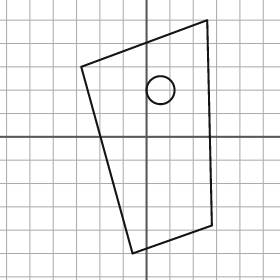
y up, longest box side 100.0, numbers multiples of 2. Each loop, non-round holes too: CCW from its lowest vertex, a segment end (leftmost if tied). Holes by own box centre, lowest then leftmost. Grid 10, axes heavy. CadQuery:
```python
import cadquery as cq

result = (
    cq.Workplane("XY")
    .moveTo(-6.0, -50.0)
    .lineTo(28.0, -38.0)
    .lineTo(26.0, 50.0)
    .lineTo(-28.0, 30.0)
    .close()
    .moveTo(6.0, 20.0)
    .circle(6.0)
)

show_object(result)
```